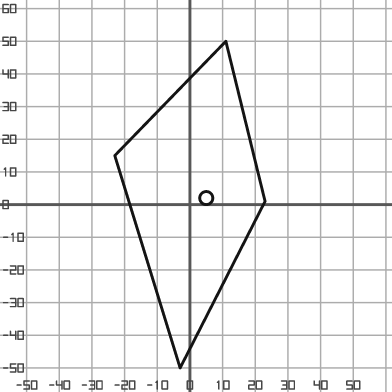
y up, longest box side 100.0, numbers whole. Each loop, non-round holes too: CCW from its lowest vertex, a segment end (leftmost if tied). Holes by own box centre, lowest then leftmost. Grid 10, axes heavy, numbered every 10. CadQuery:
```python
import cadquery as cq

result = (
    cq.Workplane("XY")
    .moveTo(-3.0, -50.0)
    .lineTo(23.0, 1.0)
    .lineTo(11.0, 50.0)
    .lineTo(-23.0, 15.0)
    .close()
    .moveTo(5.0, 2.0)
    .circle(2.0)
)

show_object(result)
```